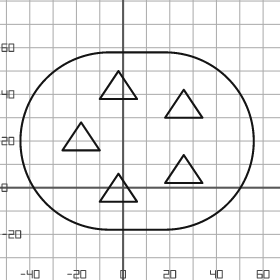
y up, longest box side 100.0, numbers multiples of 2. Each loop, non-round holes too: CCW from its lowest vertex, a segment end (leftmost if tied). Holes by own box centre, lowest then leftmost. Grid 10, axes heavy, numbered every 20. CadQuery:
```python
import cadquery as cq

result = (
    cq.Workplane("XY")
    .moveTo(-6.0, -18.0)
    .lineTo(18.0, -18.0)
    .threePointArc((56.0, 20.0), (18.0, 58.0))
    .lineTo(-6.0, 58.0)
    .threePointArc((-44.0, 20.0), (-6.0, -18.0))
    .close()
    .moveTo(-10.0, -6.0)
    .lineTo(6.0, -6.0)
    .lineTo(-2.0, 6.0)
    .close()
    .moveTo(18.0, 2.0)
    .lineTo(34.0, 2.0)
    .lineTo(26.0, 14.0)
    .close()
    .moveTo(-26.0, 16.0)
    .lineTo(-10.0, 16.0)
    .lineTo(-18.0, 28.0)
    .close()
    .moveTo(18.0, 30.0)
    .lineTo(34.0, 30.0)
    .lineTo(26.0, 42.0)
    .close()
    .moveTo(-10.0, 38.0)
    .lineTo(6.0, 38.0)
    .lineTo(-2.0, 50.0)
    .close()
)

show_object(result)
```